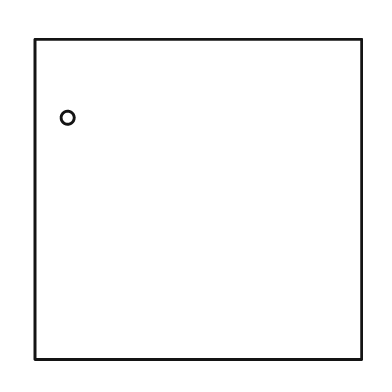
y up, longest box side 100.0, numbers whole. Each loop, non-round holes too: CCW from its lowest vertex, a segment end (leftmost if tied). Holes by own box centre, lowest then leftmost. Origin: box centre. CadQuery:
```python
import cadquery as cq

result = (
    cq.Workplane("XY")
    .moveTo(-50.0, -49.0)
    .lineTo(50.0, -49.0)
    .lineTo(50.0, 49.0)
    .lineTo(-50.0, 49.0)
    .close()
    .moveTo(-40.0, 25.0)
    .circle(2.0)
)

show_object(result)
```